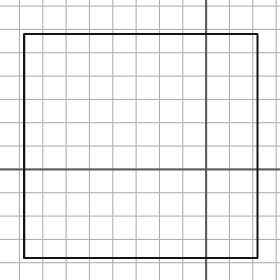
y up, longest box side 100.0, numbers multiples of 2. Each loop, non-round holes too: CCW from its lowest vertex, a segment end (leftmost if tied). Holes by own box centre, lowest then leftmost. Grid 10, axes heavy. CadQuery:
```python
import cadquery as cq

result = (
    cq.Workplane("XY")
    .moveTo(-78.0, -38.0)
    .lineTo(22.0, -38.0)
    .lineTo(22.0, 58.0)
    .lineTo(-78.0, 58.0)
    .close()
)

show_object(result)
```